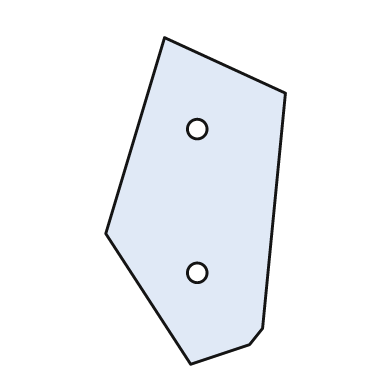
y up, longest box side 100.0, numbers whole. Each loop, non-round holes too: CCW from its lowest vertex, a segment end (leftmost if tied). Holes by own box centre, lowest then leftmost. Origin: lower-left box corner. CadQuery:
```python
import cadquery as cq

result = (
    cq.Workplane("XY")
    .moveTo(26.0, 0.0)
    .lineTo(44.0, 6.0)
    .lineTo(48.0, 11.0)
    .lineTo(55.0, 83.0)
    .lineTo(18.0, 100.0)
    .lineTo(0.0, 40.0)
    .close()
    .moveTo(28.0, 28.0)
    .circle(3.0)
    .moveTo(28.0, 72.0)
    .circle(3.0)
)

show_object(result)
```